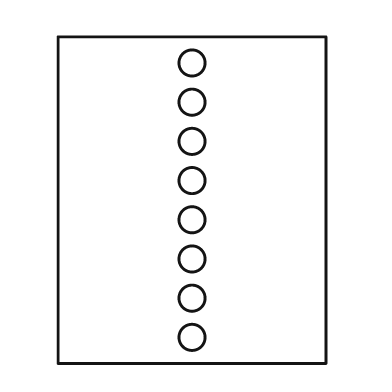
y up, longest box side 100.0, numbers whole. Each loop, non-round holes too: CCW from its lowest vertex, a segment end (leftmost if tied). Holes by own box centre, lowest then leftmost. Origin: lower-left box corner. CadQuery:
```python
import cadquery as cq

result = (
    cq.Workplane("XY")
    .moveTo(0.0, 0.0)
    .lineTo(82.0, 0.0)
    .lineTo(82.0, 100.0)
    .lineTo(0.0, 100.0)
    .close()
    .moveTo(41.0, 8.0)
    .circle(4.0)
    .moveTo(41.0, 20.0)
    .circle(4.0)
    .moveTo(41.0, 32.0)
    .circle(4.0)
    .moveTo(41.0, 44.0)
    .circle(4.0)
    .moveTo(41.0, 56.0)
    .circle(4.0)
    .moveTo(41.0, 68.0)
    .circle(4.0)
    .moveTo(41.0, 80.0)
    .circle(4.0)
    .moveTo(41.0, 92.0)
    .circle(4.0)
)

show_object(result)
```